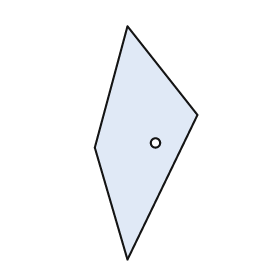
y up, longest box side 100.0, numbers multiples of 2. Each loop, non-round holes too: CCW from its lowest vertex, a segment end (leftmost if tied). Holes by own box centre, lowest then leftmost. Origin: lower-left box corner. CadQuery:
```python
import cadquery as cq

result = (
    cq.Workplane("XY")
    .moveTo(14.0, 0.0)
    .lineTo(44.0, 62.0)
    .lineTo(14.0, 100.0)
    .lineTo(0.0, 48.0)
    .close()
    .moveTo(26.0, 50.0)
    .circle(2.0)
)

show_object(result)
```